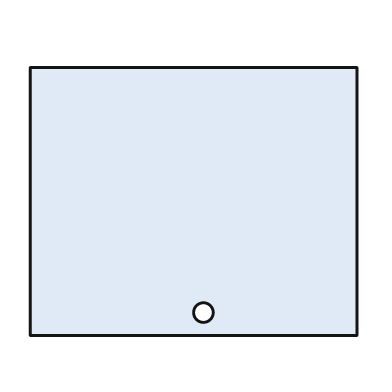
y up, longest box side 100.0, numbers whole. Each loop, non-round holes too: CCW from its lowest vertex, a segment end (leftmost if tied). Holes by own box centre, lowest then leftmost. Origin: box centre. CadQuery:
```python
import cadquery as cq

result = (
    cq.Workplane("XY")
    .moveTo(-50.0, -41.0)
    .lineTo(50.0, -41.0)
    .lineTo(50.0, 41.0)
    .lineTo(-50.0, 41.0)
    .close()
    .moveTo(3.0, -34.0)
    .circle(3.0)
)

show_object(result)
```